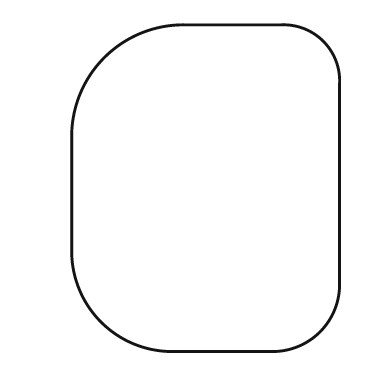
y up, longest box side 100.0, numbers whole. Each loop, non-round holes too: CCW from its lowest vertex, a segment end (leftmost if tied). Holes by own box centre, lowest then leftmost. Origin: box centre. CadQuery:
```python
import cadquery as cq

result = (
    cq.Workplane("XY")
    .moveTo(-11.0, -50.0)
    .lineTo(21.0, -50.0)
    .threePointArc((35.0, -44.0), (41.0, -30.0))
    .lineTo(41.0, 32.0)
    .threePointArc((36.0, 45.0), (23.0, 50.0))
    .lineTo(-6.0, 50.0)
    .threePointArc((-31.0, 40.0), (-41.0, 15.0))
    .lineTo(-41.0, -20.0)
    .threePointArc((-32.0, -41.0), (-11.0, -50.0))
    .close()
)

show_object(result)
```